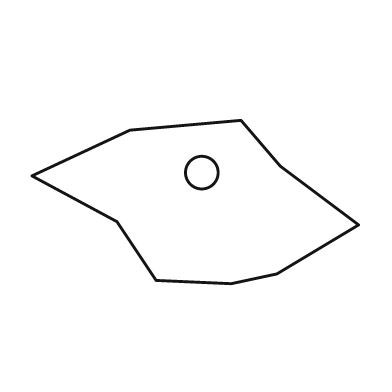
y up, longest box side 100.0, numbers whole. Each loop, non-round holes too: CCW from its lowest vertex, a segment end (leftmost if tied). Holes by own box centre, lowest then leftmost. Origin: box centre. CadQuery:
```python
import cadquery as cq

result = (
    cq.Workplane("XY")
    .moveTo(11.0, -25.0)
    .lineTo(25.0, -22.0)
    .lineTo(50.0, -7.0)
    .lineTo(26.0, 11.0)
    .lineTo(14.0, 25.0)
    .lineTo(-20.0, 22.0)
    .lineTo(-50.0, 8.0)
    .lineTo(-24.0, -6.0)
    .lineTo(-12.0, -24.0)
    .close()
    .moveTo(2.0, 9.0)
    .circle(5.0)
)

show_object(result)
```